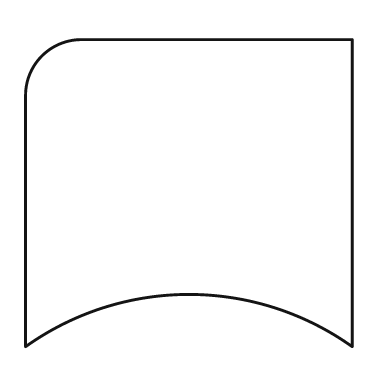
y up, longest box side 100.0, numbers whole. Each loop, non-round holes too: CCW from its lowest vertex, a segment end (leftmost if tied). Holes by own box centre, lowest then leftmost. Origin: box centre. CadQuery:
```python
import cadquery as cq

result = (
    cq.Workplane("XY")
    .moveTo(-50.0, -47.0)
    .threePointArc((0.0, -31.0), (50.0, -47.0))
    .lineTo(50.0, 47.0)
    .lineTo(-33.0, 47.0)
    .threePointArc((-45.0, 42.0), (-50.0, 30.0))
    .close()
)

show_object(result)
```